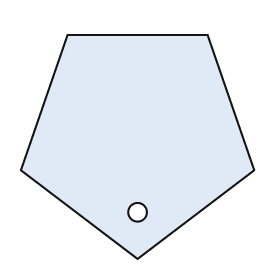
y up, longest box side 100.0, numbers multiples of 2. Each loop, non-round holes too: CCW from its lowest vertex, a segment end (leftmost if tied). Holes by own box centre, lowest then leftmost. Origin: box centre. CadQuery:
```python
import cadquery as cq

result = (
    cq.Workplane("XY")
    .moveTo(0.0, -48.0)
    .lineTo(50.0, -10.0)
    .lineTo(30.0, 48.0)
    .lineTo(-30.0, 48.0)
    .lineTo(-50.0, -10.0)
    .close()
    .moveTo(0.0, -28.0)
    .circle(4.0)
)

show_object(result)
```